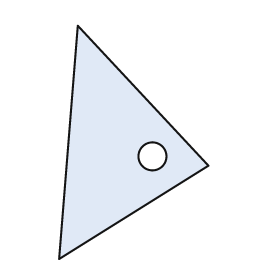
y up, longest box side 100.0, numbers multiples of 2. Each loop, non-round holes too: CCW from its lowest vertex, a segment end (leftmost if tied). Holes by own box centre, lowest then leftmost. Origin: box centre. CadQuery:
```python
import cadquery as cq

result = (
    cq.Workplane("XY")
    .moveTo(-32.0, -50.0)
    .lineTo(32.0, -10.0)
    .lineTo(-24.0, 50.0)
    .close()
    .moveTo(8.0, -6.0)
    .circle(6.0)
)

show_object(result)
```